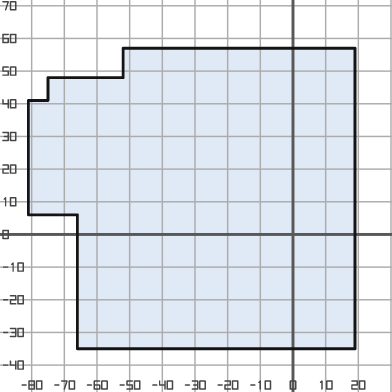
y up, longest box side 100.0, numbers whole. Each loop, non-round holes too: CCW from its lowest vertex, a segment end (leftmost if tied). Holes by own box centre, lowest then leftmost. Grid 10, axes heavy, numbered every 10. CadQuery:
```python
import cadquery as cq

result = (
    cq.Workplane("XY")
    .moveTo(-66.0, -35.0)
    .lineTo(19.0, -35.0)
    .lineTo(19.0, 57.0)
    .lineTo(-52.0, 57.0)
    .lineTo(-52.0, 48.0)
    .lineTo(-75.0, 48.0)
    .lineTo(-75.0, 41.0)
    .lineTo(-81.0, 41.0)
    .lineTo(-81.0, 6.0)
    .lineTo(-66.0, 6.0)
    .close()
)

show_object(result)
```